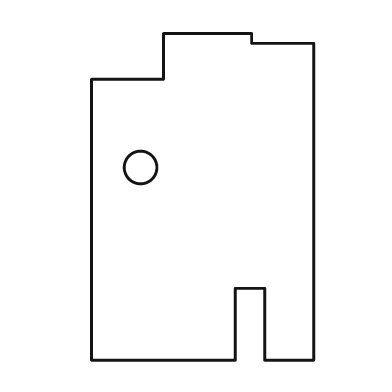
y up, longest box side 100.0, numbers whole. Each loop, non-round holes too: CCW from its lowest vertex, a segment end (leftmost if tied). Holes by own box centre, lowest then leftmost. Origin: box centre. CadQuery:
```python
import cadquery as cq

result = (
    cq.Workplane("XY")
    .moveTo(-34.0, -50.0)
    .lineTo(10.0, -50.0)
    .lineTo(10.0, -28.0)
    .lineTo(19.0, -28.0)
    .lineTo(19.0, -50.0)
    .lineTo(34.0, -50.0)
    .lineTo(34.0, 47.0)
    .lineTo(15.0, 47.0)
    .lineTo(15.0, 50.0)
    .lineTo(-12.0, 50.0)
    .lineTo(-12.0, 36.0)
    .lineTo(-34.0, 36.0)
    .close()
    .moveTo(-19.0, 9.0)
    .circle(5.0)
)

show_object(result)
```